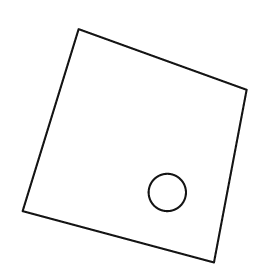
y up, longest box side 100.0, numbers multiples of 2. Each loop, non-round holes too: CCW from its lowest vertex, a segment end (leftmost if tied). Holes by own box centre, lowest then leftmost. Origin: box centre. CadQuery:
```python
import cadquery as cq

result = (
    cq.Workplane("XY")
    .moveTo(34.0, -50.0)
    .lineTo(48.0, 24.0)
    .lineTo(-24.0, 50.0)
    .lineTo(-48.0, -28.0)
    .close()
    .moveTo(14.0, -20.0)
    .circle(8.0)
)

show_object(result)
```